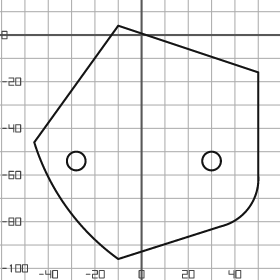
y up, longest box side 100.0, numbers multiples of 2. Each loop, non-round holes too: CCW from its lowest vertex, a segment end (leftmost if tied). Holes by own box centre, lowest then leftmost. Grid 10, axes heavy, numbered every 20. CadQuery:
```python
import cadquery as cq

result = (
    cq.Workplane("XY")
    .moveTo(-10.0, -96.0)
    .lineTo(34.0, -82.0)
    .threePointArc((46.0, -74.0), (50.0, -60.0))
    .lineTo(50.0, -16.0)
    .lineTo(-10.0, 4.0)
    .lineTo(-46.0, -46.0)
    .threePointArc((-32.0, -74.0), (-10.0, -96.0))
    .close()
    .moveTo(-28.0, -54.0)
    .circle(4.0)
    .moveTo(30.0, -54.0)
    .circle(4.0)
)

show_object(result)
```